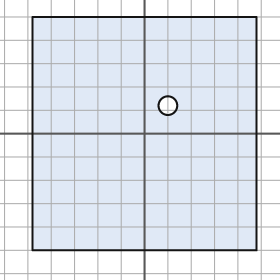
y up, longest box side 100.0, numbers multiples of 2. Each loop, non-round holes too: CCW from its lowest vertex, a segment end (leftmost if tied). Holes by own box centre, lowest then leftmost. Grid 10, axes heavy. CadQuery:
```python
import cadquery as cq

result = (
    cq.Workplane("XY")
    .moveTo(-48.0, -50.0)
    .lineTo(48.0, -50.0)
    .lineTo(48.0, 50.0)
    .lineTo(-48.0, 50.0)
    .close()
    .moveTo(10.0, 12.0)
    .circle(4.0)
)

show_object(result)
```